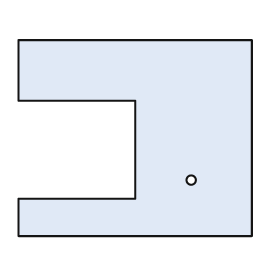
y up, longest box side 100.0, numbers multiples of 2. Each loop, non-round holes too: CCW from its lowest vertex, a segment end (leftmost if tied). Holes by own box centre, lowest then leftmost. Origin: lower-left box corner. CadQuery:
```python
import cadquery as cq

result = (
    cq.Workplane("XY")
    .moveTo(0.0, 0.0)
    .lineTo(100.0, 0.0)
    .lineTo(100.0, 84.0)
    .lineTo(0.0, 84.0)
    .lineTo(0.0, 58.0)
    .lineTo(50.0, 58.0)
    .lineTo(50.0, 16.0)
    .lineTo(0.0, 16.0)
    .close()
    .moveTo(74.0, 24.0)
    .circle(2.0)
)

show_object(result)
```